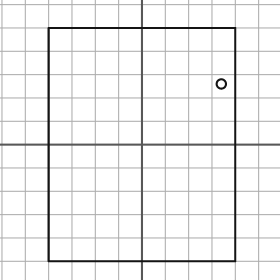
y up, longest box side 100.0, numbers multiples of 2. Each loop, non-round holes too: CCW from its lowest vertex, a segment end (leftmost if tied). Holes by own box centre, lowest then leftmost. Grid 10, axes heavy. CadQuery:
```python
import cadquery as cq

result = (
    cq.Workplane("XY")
    .moveTo(-40.0, -50.0)
    .lineTo(40.0, -50.0)
    .lineTo(40.0, 50.0)
    .lineTo(-40.0, 50.0)
    .close()
    .moveTo(34.0, 26.0)
    .circle(2.0)
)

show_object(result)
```